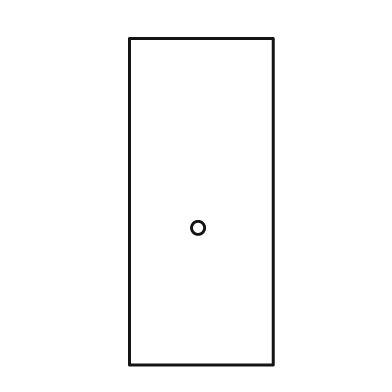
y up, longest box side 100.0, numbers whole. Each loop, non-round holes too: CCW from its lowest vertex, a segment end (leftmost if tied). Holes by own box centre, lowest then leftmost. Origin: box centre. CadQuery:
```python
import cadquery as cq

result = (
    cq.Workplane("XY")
    .moveTo(-22.0, -50.0)
    .lineTo(22.0, -50.0)
    .lineTo(22.0, 50.0)
    .lineTo(-22.0, 50.0)
    .close()
    .moveTo(-1.0, -8.0)
    .circle(2.0)
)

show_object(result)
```